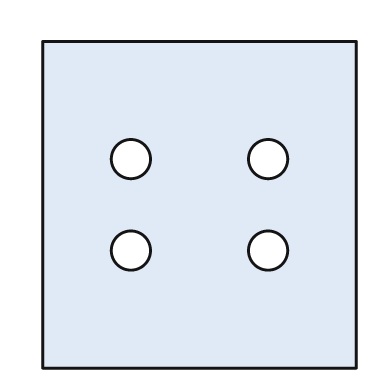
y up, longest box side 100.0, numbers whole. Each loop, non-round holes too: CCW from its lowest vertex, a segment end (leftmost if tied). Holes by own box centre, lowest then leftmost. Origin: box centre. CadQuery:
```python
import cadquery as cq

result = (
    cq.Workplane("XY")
    .moveTo(-48.0, -50.0)
    .lineTo(48.0, -50.0)
    .lineTo(48.0, 50.0)
    .lineTo(-48.0, 50.0)
    .close()
    .moveTo(-21.0, -14.0)
    .circle(6.0)
    .moveTo(21.0, -14.0)
    .circle(6.0)
    .moveTo(-21.0, 14.0)
    .circle(6.0)
    .moveTo(21.0, 14.0)
    .circle(6.0)
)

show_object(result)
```